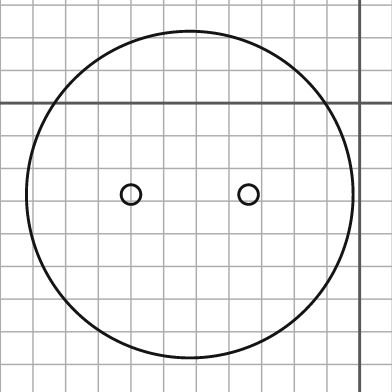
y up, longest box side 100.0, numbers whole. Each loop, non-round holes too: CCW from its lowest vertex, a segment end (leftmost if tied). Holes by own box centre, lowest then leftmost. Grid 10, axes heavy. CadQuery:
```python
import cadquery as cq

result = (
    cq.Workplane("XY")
    .moveTo(-52.0, -28.0)
    .circle(50.0)
    .moveTo(-70.0, -28.0)
    .circle(3.0)
    .moveTo(-34.0, -28.0)
    .circle(3.0)
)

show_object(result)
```